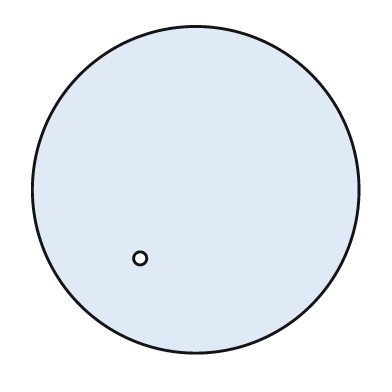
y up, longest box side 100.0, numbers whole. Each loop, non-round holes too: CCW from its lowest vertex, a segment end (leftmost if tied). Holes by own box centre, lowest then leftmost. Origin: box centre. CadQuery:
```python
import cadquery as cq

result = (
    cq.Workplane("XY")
    .moveTo(0.0, 0.0)
    .circle(50.0)
    .moveTo(-17.0, -21.0)
    .circle(2.0)
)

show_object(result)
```